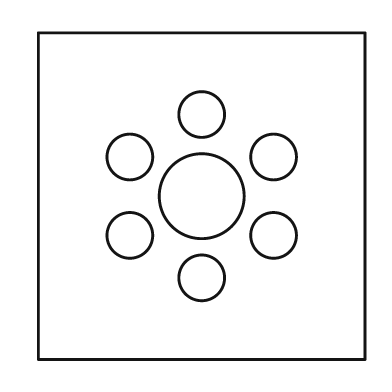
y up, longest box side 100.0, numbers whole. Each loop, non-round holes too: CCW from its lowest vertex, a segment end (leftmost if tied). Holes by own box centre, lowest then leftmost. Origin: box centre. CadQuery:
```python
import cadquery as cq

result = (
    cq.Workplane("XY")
    .moveTo(-50.0, -50.0)
    .lineTo(50.0, -50.0)
    .lineTo(50.0, 50.0)
    .lineTo(-50.0, 50.0)
    .close()
    .moveTo(0.0, -25.0)
    .circle(7.0)
    .moveTo(-22.0, -12.0)
    .circle(7.0)
    .moveTo(22.0, -12.0)
    .circle(7.0)
    .moveTo(0.0, 0.0)
    .circle(13.0)
    .moveTo(-22.0, 12.0)
    .circle(7.0)
    .moveTo(22.0, 12.0)
    .circle(7.0)
    .moveTo(0.0, 25.0)
    .circle(7.0)
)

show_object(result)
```